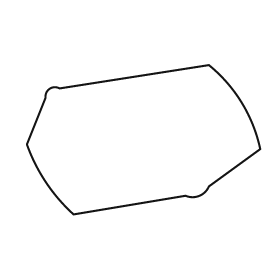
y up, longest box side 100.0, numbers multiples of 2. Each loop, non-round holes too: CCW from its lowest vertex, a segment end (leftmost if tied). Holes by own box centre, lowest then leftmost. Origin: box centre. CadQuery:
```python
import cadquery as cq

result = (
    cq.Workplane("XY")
    .moveTo(-30.0, -32.0)
    .lineTo(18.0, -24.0)
    .threePointArc((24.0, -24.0), (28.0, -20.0))
    .lineTo(50.0, -4.0)
    .threePointArc((42.0, 16.0), (28.0, 32.0))
    .lineTo(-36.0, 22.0)
    .threePointArc((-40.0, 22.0), (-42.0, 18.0))
    .lineTo(-50.0, -2.0)
    .threePointArc((-42.0, -18.0), (-30.0, -32.0))
    .close()
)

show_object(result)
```